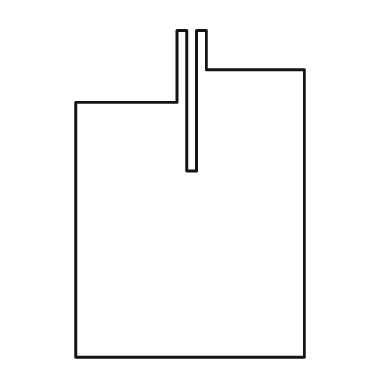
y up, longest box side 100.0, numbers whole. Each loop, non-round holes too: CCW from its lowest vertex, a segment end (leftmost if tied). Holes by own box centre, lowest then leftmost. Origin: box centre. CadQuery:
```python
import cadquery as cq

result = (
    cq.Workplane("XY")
    .moveTo(-35.0, -50.0)
    .lineTo(35.0, -50.0)
    .lineTo(35.0, 38.0)
    .lineTo(5.0, 38.0)
    .lineTo(5.0, 50.0)
    .lineTo(2.0, 50.0)
    .lineTo(2.0, 7.0)
    .lineTo(-1.0, 7.0)
    .lineTo(-1.0, 50.0)
    .lineTo(-4.0, 50.0)
    .lineTo(-4.0, 28.0)
    .lineTo(-35.0, 28.0)
    .close()
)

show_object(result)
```